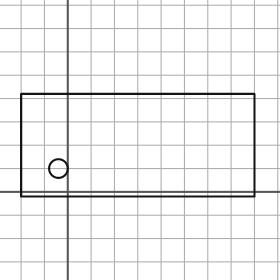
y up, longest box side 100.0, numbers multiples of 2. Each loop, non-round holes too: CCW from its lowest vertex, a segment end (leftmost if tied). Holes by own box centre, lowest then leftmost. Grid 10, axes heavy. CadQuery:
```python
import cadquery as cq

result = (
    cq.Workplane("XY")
    .moveTo(-20.0, -2.0)
    .lineTo(80.0, -2.0)
    .lineTo(80.0, 42.0)
    .lineTo(-20.0, 42.0)
    .close()
    .moveTo(-4.0, 10.0)
    .circle(4.0)
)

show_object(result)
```